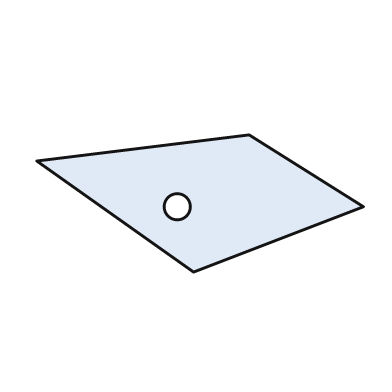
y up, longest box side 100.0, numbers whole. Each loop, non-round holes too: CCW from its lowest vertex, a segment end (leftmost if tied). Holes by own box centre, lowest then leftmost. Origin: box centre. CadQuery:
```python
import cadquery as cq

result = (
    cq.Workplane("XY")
    .moveTo(-2.0, -21.0)
    .lineTo(50.0, -1.0)
    .lineTo(15.0, 21.0)
    .lineTo(-50.0, 13.0)
    .close()
    .moveTo(-7.0, -1.0)
    .circle(4.0)
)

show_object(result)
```